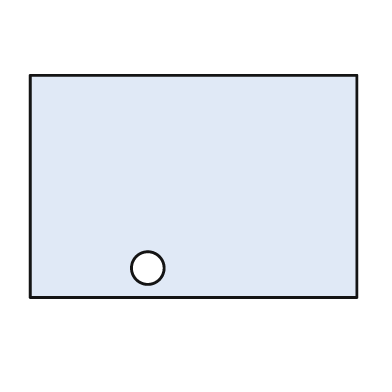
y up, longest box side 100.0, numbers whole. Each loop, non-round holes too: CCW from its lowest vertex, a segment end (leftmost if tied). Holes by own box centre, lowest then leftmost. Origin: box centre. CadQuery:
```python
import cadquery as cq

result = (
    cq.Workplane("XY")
    .moveTo(-50.0, -34.0)
    .lineTo(50.0, -34.0)
    .lineTo(50.0, 34.0)
    .lineTo(-50.0, 34.0)
    .close()
    .moveTo(-14.0, -25.0)
    .circle(5.0)
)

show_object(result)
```